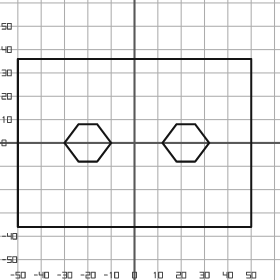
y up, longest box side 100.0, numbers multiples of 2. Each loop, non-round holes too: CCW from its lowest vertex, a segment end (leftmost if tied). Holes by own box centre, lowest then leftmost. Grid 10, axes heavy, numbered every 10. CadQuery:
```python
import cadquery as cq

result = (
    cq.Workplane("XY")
    .moveTo(-50.0, -36.0)
    .lineTo(50.0, -36.0)
    .lineTo(50.0, 36.0)
    .lineTo(-50.0, 36.0)
    .close()
    .moveTo(-24.0, -8.0)
    .lineTo(-16.0, -8.0)
    .lineTo(-10.0, 0.0)
    .lineTo(-16.0, 8.0)
    .lineTo(-24.0, 8.0)
    .lineTo(-30.0, 0.0)
    .close()
    .moveTo(18.0, -8.0)
    .lineTo(26.0, -8.0)
    .lineTo(32.0, 0.0)
    .lineTo(26.0, 8.0)
    .lineTo(18.0, 8.0)
    .lineTo(12.0, 0.0)
    .close()
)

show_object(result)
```